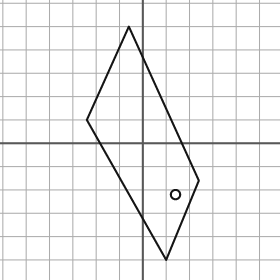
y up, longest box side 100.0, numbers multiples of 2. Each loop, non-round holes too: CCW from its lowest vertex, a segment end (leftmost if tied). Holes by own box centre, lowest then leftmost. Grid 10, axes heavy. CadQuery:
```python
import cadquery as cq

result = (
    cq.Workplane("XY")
    .moveTo(10.0, -50.0)
    .lineTo(24.0, -16.0)
    .lineTo(-6.0, 50.0)
    .lineTo(-24.0, 10.0)
    .close()
    .moveTo(14.0, -22.0)
    .circle(2.0)
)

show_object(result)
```